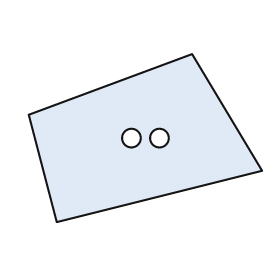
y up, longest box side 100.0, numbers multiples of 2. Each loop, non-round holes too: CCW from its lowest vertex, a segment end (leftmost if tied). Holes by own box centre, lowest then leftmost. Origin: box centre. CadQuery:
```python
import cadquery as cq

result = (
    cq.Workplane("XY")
    .moveTo(-38.0, -36.0)
    .lineTo(50.0, -14.0)
    .lineTo(20.0, 36.0)
    .lineTo(-50.0, 10.0)
    .close()
    .moveTo(-6.0, 0.0)
    .circle(4.0)
    .moveTo(6.0, 0.0)
    .circle(4.0)
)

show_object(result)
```